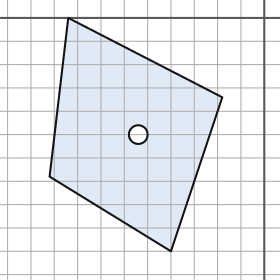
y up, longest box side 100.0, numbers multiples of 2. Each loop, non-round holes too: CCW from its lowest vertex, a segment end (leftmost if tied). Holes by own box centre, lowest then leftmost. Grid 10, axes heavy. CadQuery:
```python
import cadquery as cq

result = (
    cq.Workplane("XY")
    .moveTo(-40.0, -100.0)
    .lineTo(-18.0, -34.0)
    .lineTo(-84.0, 0.0)
    .lineTo(-92.0, -68.0)
    .close()
    .moveTo(-54.0, -50.0)
    .circle(4.0)
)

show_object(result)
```